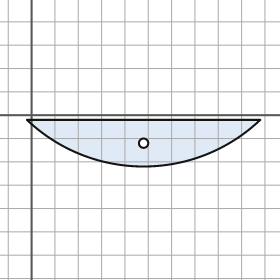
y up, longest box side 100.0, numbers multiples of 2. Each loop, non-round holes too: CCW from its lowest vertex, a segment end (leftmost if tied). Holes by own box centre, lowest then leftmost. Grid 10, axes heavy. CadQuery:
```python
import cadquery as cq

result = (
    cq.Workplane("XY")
    .moveTo(-2.0, -2.0)
    .threePointArc((48.0, -22.0), (98.0, -2.0))
    .close()
    .moveTo(48.0, -12.0)
    .circle(2.0)
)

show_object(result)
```